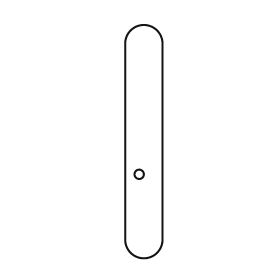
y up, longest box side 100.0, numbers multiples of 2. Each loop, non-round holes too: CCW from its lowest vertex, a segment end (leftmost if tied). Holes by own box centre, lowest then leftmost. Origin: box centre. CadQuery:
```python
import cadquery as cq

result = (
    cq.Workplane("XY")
    .moveTo(-8.0, -42.0)
    .threePointArc((0.0, -50.0), (8.0, -42.0))
    .lineTo(8.0, 42.0)
    .threePointArc((0.0, 50.0), (-8.0, 42.0))
    .close()
    .moveTo(-2.0, -14.0)
    .circle(2.0)
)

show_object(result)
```